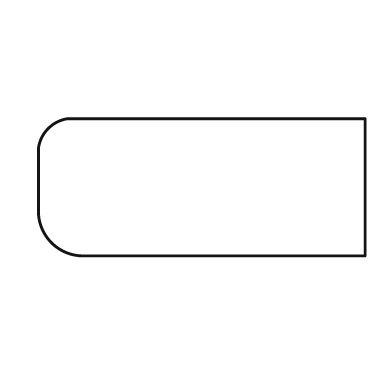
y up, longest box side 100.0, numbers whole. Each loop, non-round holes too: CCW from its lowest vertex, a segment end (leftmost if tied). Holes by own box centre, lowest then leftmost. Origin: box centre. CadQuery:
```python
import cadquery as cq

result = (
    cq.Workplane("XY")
    .moveTo(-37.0, -21.0)
    .lineTo(50.0, -21.0)
    .lineTo(50.0, 21.0)
    .lineTo(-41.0, 21.0)
    .threePointArc((-47.0, 18.0), (-50.0, 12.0))
    .lineTo(-50.0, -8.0)
    .threePointArc((-46.0, -17.0), (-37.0, -21.0))
    .close()
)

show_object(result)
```